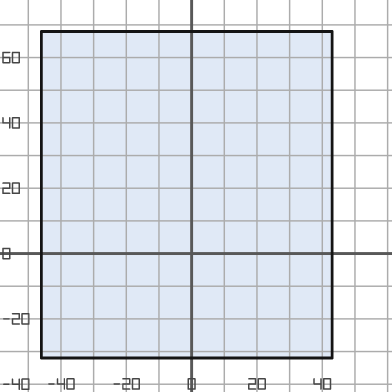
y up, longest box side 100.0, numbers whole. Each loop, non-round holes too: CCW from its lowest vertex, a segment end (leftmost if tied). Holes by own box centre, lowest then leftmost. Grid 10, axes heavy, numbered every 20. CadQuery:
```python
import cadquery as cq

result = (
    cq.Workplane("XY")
    .moveTo(-46.0, -32.0)
    .lineTo(43.0, -32.0)
    .lineTo(43.0, 68.0)
    .lineTo(-46.0, 68.0)
    .close()
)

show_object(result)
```